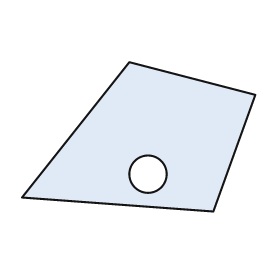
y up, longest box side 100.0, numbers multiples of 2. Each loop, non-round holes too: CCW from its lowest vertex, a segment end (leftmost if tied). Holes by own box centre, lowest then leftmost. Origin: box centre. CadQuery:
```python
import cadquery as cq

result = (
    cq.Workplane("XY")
    .moveTo(32.0, -32.0)
    .lineTo(50.0, 18.0)
    .lineTo(-4.0, 32.0)
    .lineTo(-50.0, -26.0)
    .close()
    .moveTo(4.0, -16.0)
    .circle(8.0)
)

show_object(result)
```